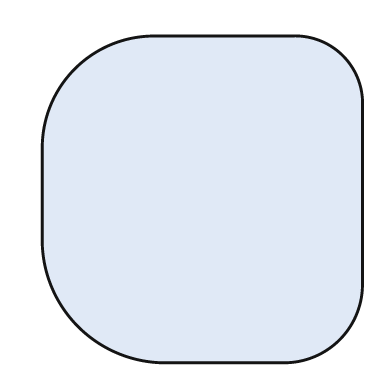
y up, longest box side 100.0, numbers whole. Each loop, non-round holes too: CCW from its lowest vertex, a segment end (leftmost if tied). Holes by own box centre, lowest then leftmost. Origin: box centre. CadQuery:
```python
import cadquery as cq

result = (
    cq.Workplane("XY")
    .moveTo(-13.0, -50.0)
    .lineTo(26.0, -50.0)
    .threePointArc((42.0, -43.0), (49.0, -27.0))
    .lineTo(49.0, 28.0)
    .threePointArc((43.0, 44.0), (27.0, 50.0))
    .lineTo(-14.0, 50.0)
    .threePointArc((-39.0, 40.0), (-49.0, 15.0))
    .lineTo(-49.0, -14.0)
    .threePointArc((-38.0, -39.0), (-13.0, -50.0))
    .close()
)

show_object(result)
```